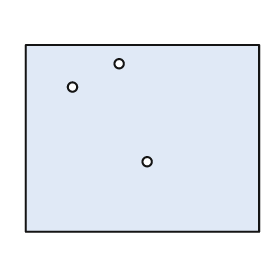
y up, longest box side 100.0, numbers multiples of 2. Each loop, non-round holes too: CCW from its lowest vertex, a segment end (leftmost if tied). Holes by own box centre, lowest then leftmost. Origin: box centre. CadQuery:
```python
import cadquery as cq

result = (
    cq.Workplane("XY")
    .moveTo(-50.0, -40.0)
    .lineTo(50.0, -40.0)
    .lineTo(50.0, 40.0)
    .lineTo(-50.0, 40.0)
    .close()
    .moveTo(2.0, -10.0)
    .circle(2.0)
    .moveTo(-30.0, 22.0)
    .circle(2.0)
    .moveTo(-10.0, 32.0)
    .circle(2.0)
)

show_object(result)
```